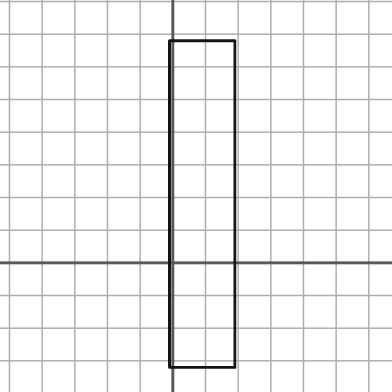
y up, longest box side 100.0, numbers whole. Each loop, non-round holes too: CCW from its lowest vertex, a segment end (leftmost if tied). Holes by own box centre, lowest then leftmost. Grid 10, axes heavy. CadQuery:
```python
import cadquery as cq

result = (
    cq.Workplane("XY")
    .moveTo(-1.0, -32.0)
    .lineTo(19.0, -32.0)
    .lineTo(19.0, 68.0)
    .lineTo(-1.0, 68.0)
    .close()
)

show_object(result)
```